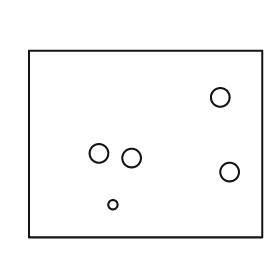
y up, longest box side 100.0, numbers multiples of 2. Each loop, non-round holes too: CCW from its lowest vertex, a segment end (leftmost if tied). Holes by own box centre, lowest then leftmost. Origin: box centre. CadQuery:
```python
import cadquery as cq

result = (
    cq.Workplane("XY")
    .moveTo(-50.0, -40.0)
    .lineTo(50.0, -40.0)
    .lineTo(50.0, 40.0)
    .lineTo(-50.0, 40.0)
    .close()
    .moveTo(-14.0, -26.0)
    .circle(2.0)
    .moveTo(36.0, -12.0)
    .circle(4.0)
    .moveTo(-6.0, -6.0)
    .circle(4.0)
    .moveTo(-20.0, -4.0)
    .circle(4.0)
    .moveTo(32.0, 20.0)
    .circle(4.0)
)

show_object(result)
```